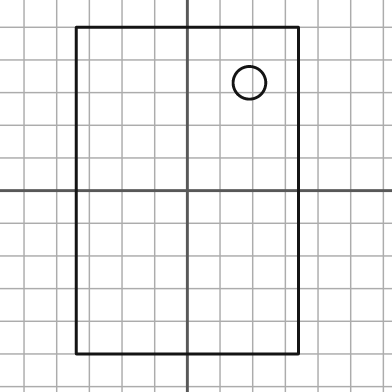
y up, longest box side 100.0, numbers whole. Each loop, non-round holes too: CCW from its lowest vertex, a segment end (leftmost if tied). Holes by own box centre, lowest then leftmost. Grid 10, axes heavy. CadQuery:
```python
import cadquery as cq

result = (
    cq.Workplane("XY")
    .moveTo(-34.0, -50.0)
    .lineTo(34.0, -50.0)
    .lineTo(34.0, 50.0)
    .lineTo(-34.0, 50.0)
    .close()
    .moveTo(19.0, 33.0)
    .circle(5.0)
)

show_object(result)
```